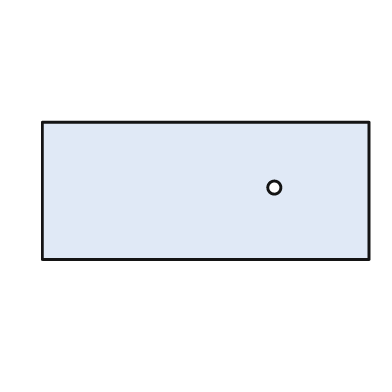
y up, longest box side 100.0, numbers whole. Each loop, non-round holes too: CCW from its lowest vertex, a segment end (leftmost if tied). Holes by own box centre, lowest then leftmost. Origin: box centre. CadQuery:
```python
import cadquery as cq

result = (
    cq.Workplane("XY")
    .moveTo(-50.0, -21.0)
    .lineTo(50.0, -21.0)
    .lineTo(50.0, 21.0)
    .lineTo(-50.0, 21.0)
    .close()
    .moveTo(21.0, 1.0)
    .circle(2.0)
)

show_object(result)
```